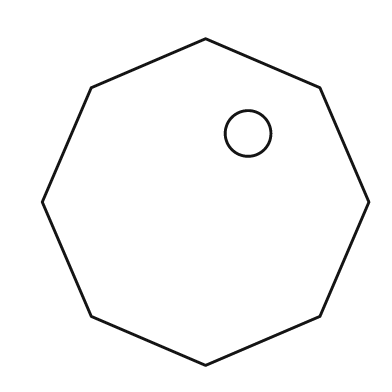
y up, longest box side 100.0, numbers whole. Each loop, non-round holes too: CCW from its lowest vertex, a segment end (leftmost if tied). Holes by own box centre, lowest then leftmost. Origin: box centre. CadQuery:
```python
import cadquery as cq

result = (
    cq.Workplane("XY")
    .moveTo(0.0, -50.0)
    .lineTo(35.0, -35.0)
    .lineTo(50.0, 0.0)
    .lineTo(35.0, 35.0)
    .lineTo(0.0, 50.0)
    .lineTo(-35.0, 35.0)
    .lineTo(-50.0, 0.0)
    .lineTo(-35.0, -35.0)
    .close()
    .moveTo(13.0, 21.0)
    .circle(7.0)
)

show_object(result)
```